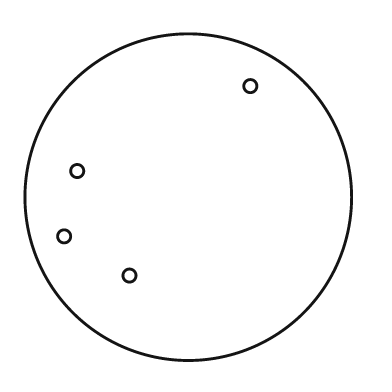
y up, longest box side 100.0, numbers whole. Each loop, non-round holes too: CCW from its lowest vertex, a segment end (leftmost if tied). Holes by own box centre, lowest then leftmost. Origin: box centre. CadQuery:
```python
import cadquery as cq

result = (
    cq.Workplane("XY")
    .moveTo(0.0, 0.0)
    .circle(50.0)
    .moveTo(-18.0, -24.0)
    .circle(2.0)
    .moveTo(-38.0, -12.0)
    .circle(2.0)
    .moveTo(-34.0, 8.0)
    .circle(2.0)
    .moveTo(19.0, 34.0)
    .circle(2.0)
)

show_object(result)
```